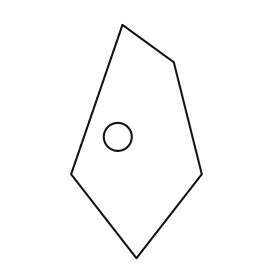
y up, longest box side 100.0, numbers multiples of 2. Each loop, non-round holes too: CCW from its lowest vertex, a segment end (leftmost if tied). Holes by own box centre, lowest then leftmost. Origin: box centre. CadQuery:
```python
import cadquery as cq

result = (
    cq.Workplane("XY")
    .moveTo(0.0, -50.0)
    .lineTo(28.0, -14.0)
    .lineTo(16.0, 34.0)
    .lineTo(-6.0, 50.0)
    .lineTo(-28.0, -14.0)
    .close()
    .moveTo(-8.0, 2.0)
    .circle(6.0)
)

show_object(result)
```